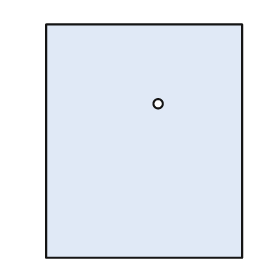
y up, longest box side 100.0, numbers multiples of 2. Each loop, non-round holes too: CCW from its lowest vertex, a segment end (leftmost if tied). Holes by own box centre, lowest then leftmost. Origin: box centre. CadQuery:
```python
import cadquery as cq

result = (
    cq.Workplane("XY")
    .moveTo(-42.0, -50.0)
    .lineTo(42.0, -50.0)
    .lineTo(42.0, 50.0)
    .lineTo(-42.0, 50.0)
    .close()
    .moveTo(6.0, 16.0)
    .circle(2.0)
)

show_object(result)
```